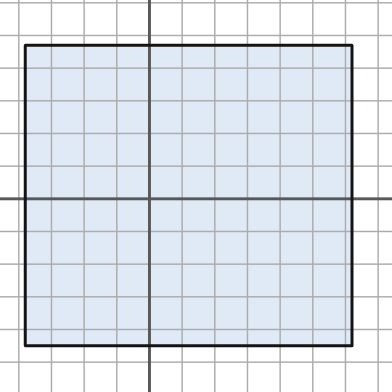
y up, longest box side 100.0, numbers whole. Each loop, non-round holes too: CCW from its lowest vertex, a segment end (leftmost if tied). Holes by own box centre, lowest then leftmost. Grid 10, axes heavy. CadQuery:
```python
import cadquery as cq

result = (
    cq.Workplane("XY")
    .moveTo(-38.0, -45.0)
    .lineTo(62.0, -45.0)
    .lineTo(62.0, 47.0)
    .lineTo(-38.0, 47.0)
    .close()
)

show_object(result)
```